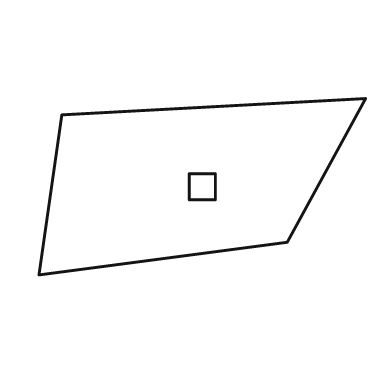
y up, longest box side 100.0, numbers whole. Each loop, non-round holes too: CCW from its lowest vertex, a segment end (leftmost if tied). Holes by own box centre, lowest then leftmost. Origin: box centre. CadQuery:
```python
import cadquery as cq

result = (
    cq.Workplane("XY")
    .moveTo(-50.0, -27.0)
    .lineTo(26.0, -17.0)
    .lineTo(50.0, 27.0)
    .lineTo(-43.0, 22.0)
    .close()
    .moveTo(-4.0, -4.0)
    .lineTo(4.0, -4.0)
    .lineTo(4.0, 4.0)
    .lineTo(-4.0, 4.0)
    .close()
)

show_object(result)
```